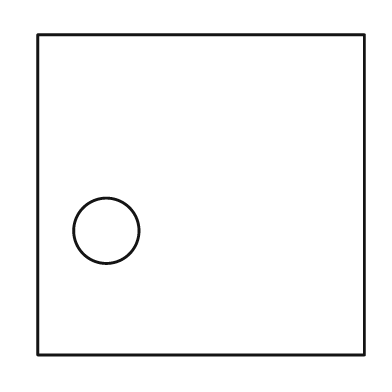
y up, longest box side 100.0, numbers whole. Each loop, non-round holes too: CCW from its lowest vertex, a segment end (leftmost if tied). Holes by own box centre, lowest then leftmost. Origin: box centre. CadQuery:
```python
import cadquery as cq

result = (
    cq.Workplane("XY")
    .moveTo(-50.0, -49.0)
    .lineTo(50.0, -49.0)
    .lineTo(50.0, 49.0)
    .lineTo(-50.0, 49.0)
    .close()
    .moveTo(-29.0, -11.0)
    .circle(10.0)
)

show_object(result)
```